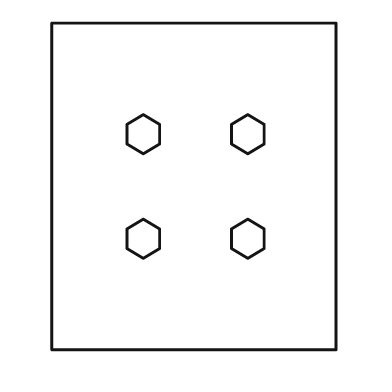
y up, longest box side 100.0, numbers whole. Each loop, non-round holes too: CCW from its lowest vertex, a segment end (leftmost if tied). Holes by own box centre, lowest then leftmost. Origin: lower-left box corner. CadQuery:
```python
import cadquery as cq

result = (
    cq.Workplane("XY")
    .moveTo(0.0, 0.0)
    .lineTo(87.0, 0.0)
    .lineTo(87.0, 100.0)
    .lineTo(0.0, 100.0)
    .close()
    .moveTo(28.0, 28.0)
    .lineTo(33.0, 31.0)
    .lineTo(33.0, 37.0)
    .lineTo(28.0, 40.0)
    .lineTo(23.0, 37.0)
    .lineTo(23.0, 31.0)
    .close()
    .moveTo(60.0, 28.0)
    .lineTo(65.0, 31.0)
    .lineTo(65.0, 37.0)
    .lineTo(60.0, 40.0)
    .lineTo(55.0, 37.0)
    .lineTo(55.0, 31.0)
    .close()
    .moveTo(28.0, 60.0)
    .lineTo(33.0, 63.0)
    .lineTo(33.0, 69.0)
    .lineTo(28.0, 72.0)
    .lineTo(23.0, 69.0)
    .lineTo(23.0, 63.0)
    .close()
    .moveTo(60.0, 60.0)
    .lineTo(65.0, 63.0)
    .lineTo(65.0, 69.0)
    .lineTo(60.0, 72.0)
    .lineTo(55.0, 69.0)
    .lineTo(55.0, 63.0)
    .close()
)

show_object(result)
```